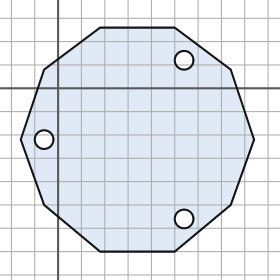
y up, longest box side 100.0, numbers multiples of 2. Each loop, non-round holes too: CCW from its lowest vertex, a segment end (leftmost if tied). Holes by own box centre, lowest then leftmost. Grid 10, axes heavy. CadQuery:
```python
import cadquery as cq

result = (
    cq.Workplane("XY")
    .moveTo(18.0, -70.0)
    .lineTo(50.0, -70.0)
    .lineTo(74.0, -50.0)
    .lineTo(84.0, -22.0)
    .lineTo(74.0, 8.0)
    .lineTo(50.0, 26.0)
    .lineTo(18.0, 26.0)
    .lineTo(-6.0, 8.0)
    .lineTo(-16.0, -22.0)
    .lineTo(-6.0, -50.0)
    .close()
    .moveTo(54.0, -56.0)
    .circle(4.0)
    .moveTo(-6.0, -22.0)
    .circle(4.0)
    .moveTo(54.0, 12.0)
    .circle(4.0)
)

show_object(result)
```